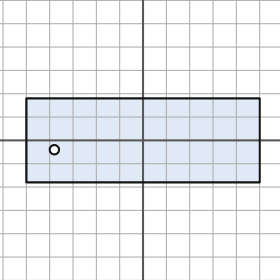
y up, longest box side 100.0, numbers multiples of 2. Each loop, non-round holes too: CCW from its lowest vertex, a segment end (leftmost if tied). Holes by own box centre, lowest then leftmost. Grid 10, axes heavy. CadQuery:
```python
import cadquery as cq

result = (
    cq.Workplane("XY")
    .moveTo(-50.0, -18.0)
    .lineTo(50.0, -18.0)
    .lineTo(50.0, 18.0)
    .lineTo(-50.0, 18.0)
    .close()
    .moveTo(-38.0, -4.0)
    .circle(2.0)
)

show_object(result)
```